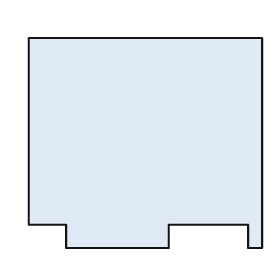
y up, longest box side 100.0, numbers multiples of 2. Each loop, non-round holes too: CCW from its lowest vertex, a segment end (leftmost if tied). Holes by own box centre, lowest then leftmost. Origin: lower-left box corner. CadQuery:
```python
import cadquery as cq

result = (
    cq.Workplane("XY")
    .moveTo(16.0, 0.0)
    .lineTo(60.0, 0.0)
    .lineTo(60.0, 10.0)
    .lineTo(94.0, 10.0)
    .lineTo(94.0, 0.0)
    .lineTo(100.0, 0.0)
    .lineTo(100.0, 90.0)
    .lineTo(0.0, 90.0)
    .lineTo(0.0, 10.0)
    .lineTo(16.0, 10.0)
    .close()
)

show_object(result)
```